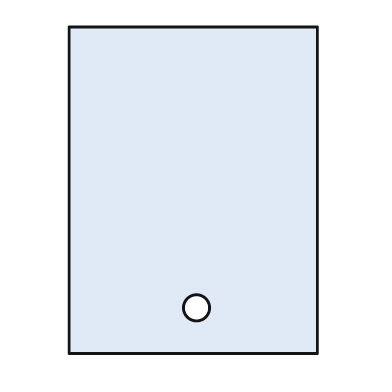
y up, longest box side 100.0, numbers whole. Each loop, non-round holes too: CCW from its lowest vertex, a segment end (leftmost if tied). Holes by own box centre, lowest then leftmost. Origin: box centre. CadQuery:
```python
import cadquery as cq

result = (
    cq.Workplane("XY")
    .moveTo(-38.0, -50.0)
    .lineTo(38.0, -50.0)
    .lineTo(38.0, 50.0)
    .lineTo(-38.0, 50.0)
    .close()
    .moveTo(1.0, -36.0)
    .circle(4.0)
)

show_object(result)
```